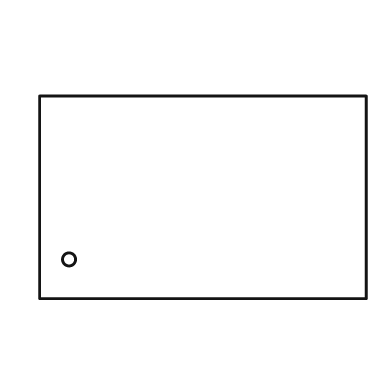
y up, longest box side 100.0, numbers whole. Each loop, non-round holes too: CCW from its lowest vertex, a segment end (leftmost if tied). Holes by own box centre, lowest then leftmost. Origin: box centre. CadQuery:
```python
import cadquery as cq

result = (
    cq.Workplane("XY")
    .moveTo(-50.0, -31.0)
    .lineTo(50.0, -31.0)
    .lineTo(50.0, 31.0)
    .lineTo(-50.0, 31.0)
    .close()
    .moveTo(-41.0, -19.0)
    .circle(2.0)
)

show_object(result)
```